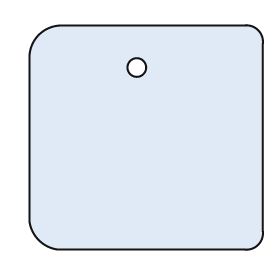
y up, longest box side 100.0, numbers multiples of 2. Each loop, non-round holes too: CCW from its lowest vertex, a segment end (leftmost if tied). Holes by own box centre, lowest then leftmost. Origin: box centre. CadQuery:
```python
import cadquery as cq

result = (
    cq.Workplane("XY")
    .moveTo(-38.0, -48.0)
    .lineTo(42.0, -48.0)
    .threePointArc((48.0, -46.0), (50.0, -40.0))
    .lineTo(50.0, 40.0)
    .threePointArc((48.0, 46.0), (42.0, 48.0))
    .lineTo(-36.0, 48.0)
    .threePointArc((-46.0, 44.0), (-50.0, 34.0))
    .lineTo(-50.0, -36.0)
    .threePointArc((-46.0, -44.0), (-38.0, -48.0))
    .close()
    .moveTo(-4.0, 30.0)
    .circle(4.0)
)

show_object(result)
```